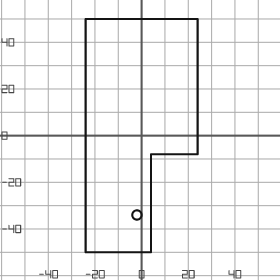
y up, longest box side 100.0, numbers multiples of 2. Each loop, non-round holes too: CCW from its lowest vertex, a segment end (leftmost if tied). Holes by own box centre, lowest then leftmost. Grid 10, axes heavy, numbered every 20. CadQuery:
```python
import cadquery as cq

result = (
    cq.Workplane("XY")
    .moveTo(-24.0, -50.0)
    .lineTo(4.0, -50.0)
    .lineTo(4.0, -8.0)
    .lineTo(24.0, -8.0)
    .lineTo(24.0, 50.0)
    .lineTo(-24.0, 50.0)
    .close()
    .moveTo(-2.0, -34.0)
    .circle(2.0)
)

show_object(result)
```